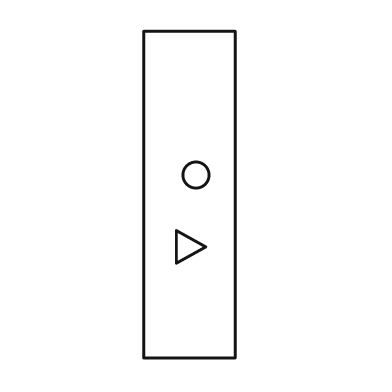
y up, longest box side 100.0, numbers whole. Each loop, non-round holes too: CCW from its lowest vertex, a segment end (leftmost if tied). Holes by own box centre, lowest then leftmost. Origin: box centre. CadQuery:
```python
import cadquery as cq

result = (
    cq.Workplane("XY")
    .moveTo(-14.0, -50.0)
    .lineTo(14.0, -50.0)
    .lineTo(14.0, 50.0)
    .lineTo(-14.0, 50.0)
    .close()
    .moveTo(-4.0, -21.0)
    .lineTo(5.0, -16.0)
    .lineTo(-4.0, -11.0)
    .close()
    .moveTo(2.0, 6.0)
    .circle(4.0)
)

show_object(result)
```